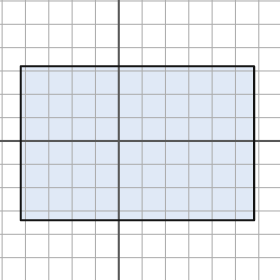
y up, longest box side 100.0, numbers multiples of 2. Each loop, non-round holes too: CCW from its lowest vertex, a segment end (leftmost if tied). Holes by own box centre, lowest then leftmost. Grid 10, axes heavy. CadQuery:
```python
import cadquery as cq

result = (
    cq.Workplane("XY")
    .moveTo(-42.0, -34.0)
    .lineTo(58.0, -34.0)
    .lineTo(58.0, 32.0)
    .lineTo(-42.0, 32.0)
    .close()
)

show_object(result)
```